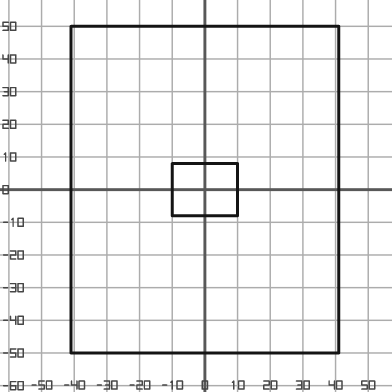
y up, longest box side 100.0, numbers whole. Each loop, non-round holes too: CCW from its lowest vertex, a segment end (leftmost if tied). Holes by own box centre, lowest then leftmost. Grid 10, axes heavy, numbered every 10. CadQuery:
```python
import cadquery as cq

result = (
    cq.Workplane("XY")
    .moveTo(-41.0, -50.0)
    .lineTo(41.0, -50.0)
    .lineTo(41.0, 50.0)
    .lineTo(-41.0, 50.0)
    .close()
    .moveTo(-10.0, -8.0)
    .lineTo(10.0, -8.0)
    .lineTo(10.0, 8.0)
    .lineTo(-10.0, 8.0)
    .close()
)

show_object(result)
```